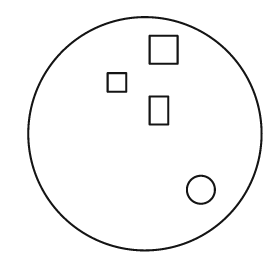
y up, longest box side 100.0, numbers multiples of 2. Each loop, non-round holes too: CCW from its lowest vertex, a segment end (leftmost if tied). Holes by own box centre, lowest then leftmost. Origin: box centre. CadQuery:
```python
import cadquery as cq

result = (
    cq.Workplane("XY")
    .moveTo(0.0, 0.0)
    .circle(50.0)
    .moveTo(24.0, -24.0)
    .circle(6.0)
    .moveTo(2.0, 4.0)
    .lineTo(10.0, 4.0)
    .lineTo(10.0, 16.0)
    .lineTo(2.0, 16.0)
    .close()
    .moveTo(-16.0, 18.0)
    .lineTo(-8.0, 18.0)
    .lineTo(-8.0, 26.0)
    .lineTo(-16.0, 26.0)
    .close()
    .moveTo(2.0, 30.0)
    .lineTo(14.0, 30.0)
    .lineTo(14.0, 42.0)
    .lineTo(2.0, 42.0)
    .close()
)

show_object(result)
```